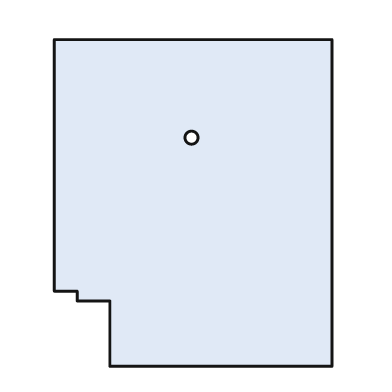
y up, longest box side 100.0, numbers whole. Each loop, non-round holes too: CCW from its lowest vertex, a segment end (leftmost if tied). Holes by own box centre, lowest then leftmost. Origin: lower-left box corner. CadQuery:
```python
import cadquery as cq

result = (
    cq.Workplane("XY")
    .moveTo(17.0, 0.0)
    .lineTo(85.0, 0.0)
    .lineTo(85.0, 100.0)
    .lineTo(0.0, 100.0)
    .lineTo(0.0, 23.0)
    .lineTo(7.0, 23.0)
    .lineTo(7.0, 20.0)
    .lineTo(17.0, 20.0)
    .close()
    .moveTo(42.0, 70.0)
    .circle(2.0)
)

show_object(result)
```